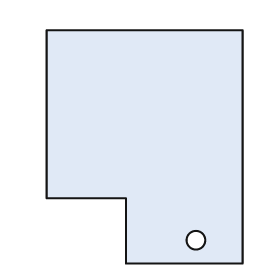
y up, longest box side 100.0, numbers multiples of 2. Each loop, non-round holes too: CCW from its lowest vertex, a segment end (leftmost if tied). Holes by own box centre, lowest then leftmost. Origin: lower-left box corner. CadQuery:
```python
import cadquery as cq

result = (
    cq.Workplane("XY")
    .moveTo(34.0, 0.0)
    .lineTo(84.0, 0.0)
    .lineTo(84.0, 100.0)
    .lineTo(0.0, 100.0)
    .lineTo(0.0, 28.0)
    .lineTo(34.0, 28.0)
    .close()
    .moveTo(64.0, 10.0)
    .circle(4.0)
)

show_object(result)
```